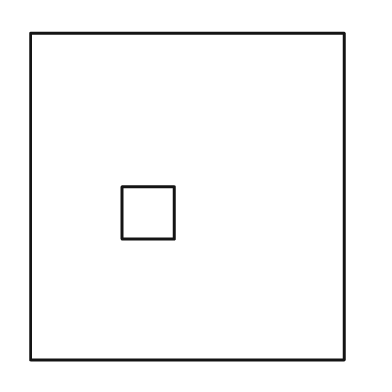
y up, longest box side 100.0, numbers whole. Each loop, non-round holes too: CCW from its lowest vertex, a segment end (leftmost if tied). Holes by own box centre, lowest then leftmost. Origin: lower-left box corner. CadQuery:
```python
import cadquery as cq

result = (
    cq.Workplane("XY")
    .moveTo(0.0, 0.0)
    .lineTo(96.0, 0.0)
    .lineTo(96.0, 100.0)
    .lineTo(0.0, 100.0)
    .close()
    .moveTo(28.0, 37.0)
    .lineTo(44.0, 37.0)
    .lineTo(44.0, 53.0)
    .lineTo(28.0, 53.0)
    .close()
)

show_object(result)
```